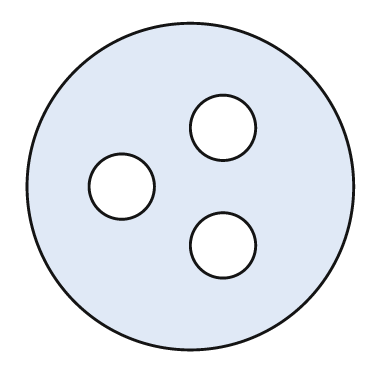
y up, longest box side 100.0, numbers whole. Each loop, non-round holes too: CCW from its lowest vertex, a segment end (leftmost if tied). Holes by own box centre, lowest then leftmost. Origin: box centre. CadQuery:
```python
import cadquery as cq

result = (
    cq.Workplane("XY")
    .moveTo(0.0, 0.0)
    .circle(50.0)
    .moveTo(10.0, -18.0)
    .circle(10.0)
    .moveTo(-21.0, 0.0)
    .circle(10.0)
    .moveTo(10.0, 18.0)
    .circle(10.0)
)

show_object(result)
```